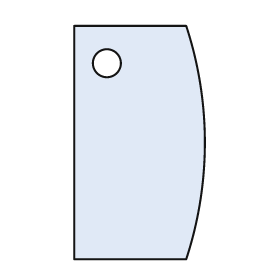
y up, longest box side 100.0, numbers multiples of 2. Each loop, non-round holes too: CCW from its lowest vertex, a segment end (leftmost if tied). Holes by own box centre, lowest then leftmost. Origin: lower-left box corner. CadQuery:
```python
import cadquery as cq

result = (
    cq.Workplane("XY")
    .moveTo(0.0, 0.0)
    .lineTo(48.0, 0.0)
    .threePointArc((56.0, 50.0), (48.0, 100.0))
    .lineTo(0.0, 100.0)
    .close()
    .moveTo(14.0, 84.0)
    .circle(6.0)
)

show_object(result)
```